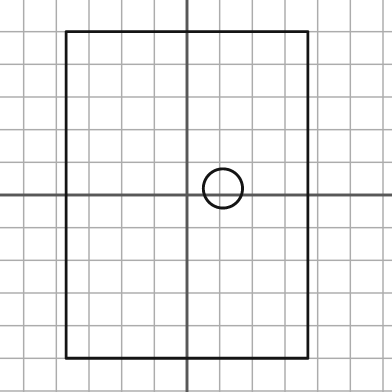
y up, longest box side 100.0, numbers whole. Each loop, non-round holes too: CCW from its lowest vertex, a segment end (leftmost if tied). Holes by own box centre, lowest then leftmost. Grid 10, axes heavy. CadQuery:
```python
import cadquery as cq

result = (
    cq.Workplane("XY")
    .moveTo(-37.0, -50.0)
    .lineTo(37.0, -50.0)
    .lineTo(37.0, 50.0)
    .lineTo(-37.0, 50.0)
    .close()
    .moveTo(11.0, 2.0)
    .circle(6.0)
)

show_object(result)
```